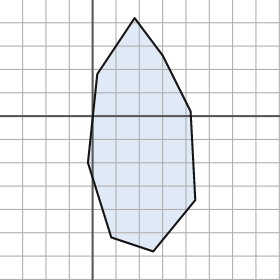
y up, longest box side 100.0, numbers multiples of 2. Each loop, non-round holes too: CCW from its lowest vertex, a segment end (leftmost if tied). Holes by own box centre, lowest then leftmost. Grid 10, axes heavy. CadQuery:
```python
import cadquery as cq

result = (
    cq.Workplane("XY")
    .moveTo(26.0, -58.0)
    .lineTo(44.0, -36.0)
    .lineTo(42.0, 2.0)
    .lineTo(30.0, 26.0)
    .lineTo(18.0, 42.0)
    .lineTo(2.0, 18.0)
    .lineTo(-2.0, -20.0)
    .lineTo(8.0, -52.0)
    .close()
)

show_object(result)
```